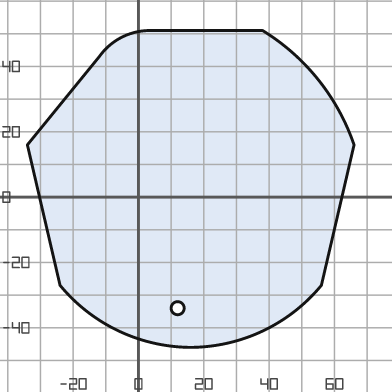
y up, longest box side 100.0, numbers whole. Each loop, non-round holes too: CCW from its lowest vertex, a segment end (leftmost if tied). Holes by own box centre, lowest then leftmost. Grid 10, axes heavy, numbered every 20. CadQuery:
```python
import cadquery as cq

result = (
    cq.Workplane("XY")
    .moveTo(16.0, -46.0)
    .threePointArc((38.0, -41.0), (56.0, -27.0))
    .lineTo(66.0, 16.0)
    .threePointArc((55.0, 36.0), (38.0, 51.0))
    .lineTo(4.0, 51.0)
    .threePointArc((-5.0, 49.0), (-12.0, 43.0))
    .lineTo(-34.0, 16.0)
    .lineTo(-24.0, -27.0)
    .threePointArc((-6.0, -41.0), (16.0, -46.0))
    .close()
    .moveTo(12.0, -34.0)
    .circle(2.0)
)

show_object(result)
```